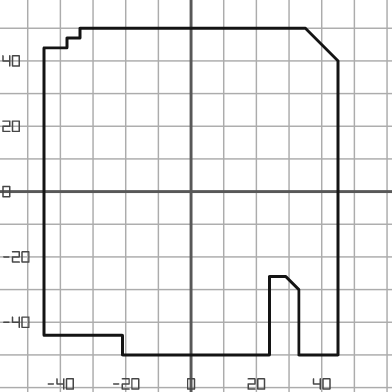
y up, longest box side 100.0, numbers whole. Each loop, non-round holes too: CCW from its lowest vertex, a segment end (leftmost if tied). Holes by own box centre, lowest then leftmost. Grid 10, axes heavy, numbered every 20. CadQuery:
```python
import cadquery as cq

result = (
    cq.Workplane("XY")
    .moveTo(-21.0, -50.0)
    .lineTo(24.0, -50.0)
    .lineTo(24.0, -26.0)
    .lineTo(29.0, -26.0)
    .lineTo(33.0, -30.0)
    .lineTo(33.0, -50.0)
    .lineTo(45.0, -50.0)
    .lineTo(45.0, 40.0)
    .lineTo(35.0, 50.0)
    .lineTo(-34.0, 50.0)
    .lineTo(-34.0, 47.0)
    .lineTo(-38.0, 47.0)
    .lineTo(-38.0, 44.0)
    .lineTo(-45.0, 44.0)
    .lineTo(-45.0, -44.0)
    .lineTo(-21.0, -44.0)
    .close()
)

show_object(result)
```